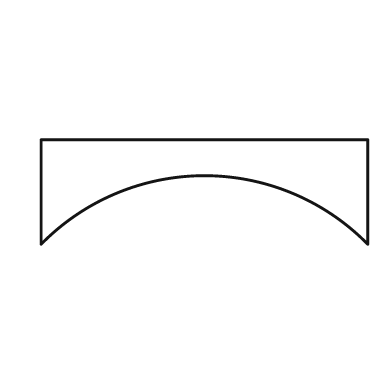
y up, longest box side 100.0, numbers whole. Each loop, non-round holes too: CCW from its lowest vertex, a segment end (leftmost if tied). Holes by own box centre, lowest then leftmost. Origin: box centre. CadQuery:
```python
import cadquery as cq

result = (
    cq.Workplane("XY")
    .moveTo(-50.0, -16.0)
    .threePointArc((0.0, 5.0), (50.0, -16.0))
    .lineTo(50.0, 16.0)
    .lineTo(-50.0, 16.0)
    .close()
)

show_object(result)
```